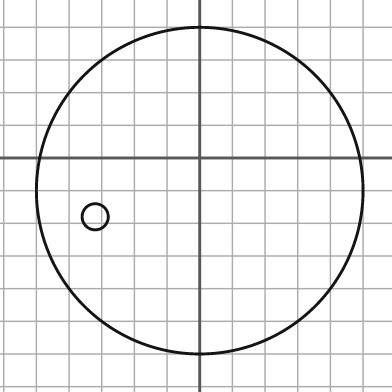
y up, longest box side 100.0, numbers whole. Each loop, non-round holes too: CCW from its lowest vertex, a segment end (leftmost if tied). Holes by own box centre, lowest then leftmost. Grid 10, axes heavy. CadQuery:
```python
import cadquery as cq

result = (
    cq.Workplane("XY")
    .moveTo(0.0, -10.0)
    .circle(50.0)
    .moveTo(-32.0, -18.0)
    .circle(4.0)
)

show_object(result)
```